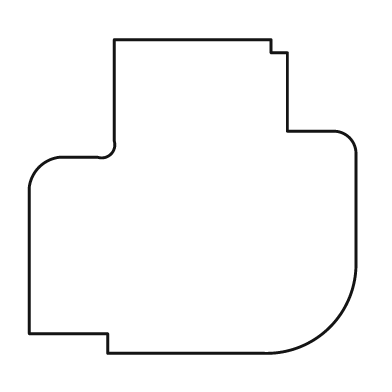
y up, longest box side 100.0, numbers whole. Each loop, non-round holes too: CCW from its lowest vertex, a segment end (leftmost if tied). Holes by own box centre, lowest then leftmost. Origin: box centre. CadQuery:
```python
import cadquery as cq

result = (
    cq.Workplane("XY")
    .moveTo(-26.0, -48.0)
    .lineTo(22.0, -48.0)
    .threePointArc((42.0, -40.0), (50.0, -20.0))
    .lineTo(50.0, 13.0)
    .threePointArc((48.0, 18.0), (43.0, 20.0))
    .lineTo(29.0, 20.0)
    .lineTo(29.0, 44.0)
    .lineTo(24.0, 44.0)
    .lineTo(24.0, 48.0)
    .lineTo(-24.0, 48.0)
    .lineTo(-24.0, 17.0)
    .threePointArc((-25.0, 13.0), (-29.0, 12.0))
    .lineTo(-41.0, 12.0)
    .threePointArc((-47.0, 9.0), (-50.0, 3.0))
    .lineTo(-50.0, -42.0)
    .lineTo(-26.0, -42.0)
    .close()
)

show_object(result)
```